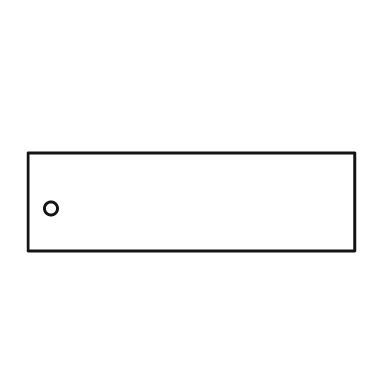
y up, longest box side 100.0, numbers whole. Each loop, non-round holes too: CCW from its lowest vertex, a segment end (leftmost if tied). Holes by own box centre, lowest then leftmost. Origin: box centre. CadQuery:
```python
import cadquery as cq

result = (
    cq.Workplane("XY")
    .moveTo(-50.0, -15.0)
    .lineTo(50.0, -15.0)
    .lineTo(50.0, 15.0)
    .lineTo(-50.0, 15.0)
    .close()
    .moveTo(-43.0, -2.0)
    .circle(2.0)
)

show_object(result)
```